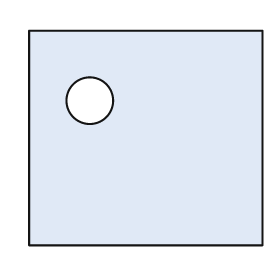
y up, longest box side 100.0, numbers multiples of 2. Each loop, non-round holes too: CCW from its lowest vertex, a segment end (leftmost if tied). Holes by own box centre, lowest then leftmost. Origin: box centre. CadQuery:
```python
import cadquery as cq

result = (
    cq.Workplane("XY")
    .moveTo(-50.0, -46.0)
    .lineTo(50.0, -46.0)
    .lineTo(50.0, 46.0)
    .lineTo(-50.0, 46.0)
    .close()
    .moveTo(-24.0, 16.0)
    .circle(10.0)
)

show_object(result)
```